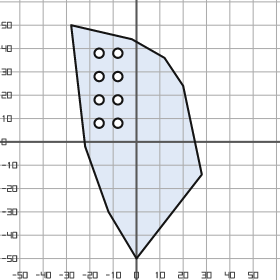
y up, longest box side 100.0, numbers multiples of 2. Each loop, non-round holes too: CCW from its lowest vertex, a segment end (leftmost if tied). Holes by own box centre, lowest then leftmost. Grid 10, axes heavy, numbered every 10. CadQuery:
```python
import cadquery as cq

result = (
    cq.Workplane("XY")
    .moveTo(0.0, -50.0)
    .lineTo(28.0, -14.0)
    .lineTo(20.0, 24.0)
    .lineTo(12.0, 36.0)
    .lineTo(-2.0, 44.0)
    .lineTo(-28.0, 50.0)
    .lineTo(-22.0, -2.0)
    .lineTo(-12.0, -30.0)
    .close()
    .moveTo(-16.0, 8.0)
    .circle(2.0)
    .moveTo(-8.0, 8.0)
    .circle(2.0)
    .moveTo(-16.0, 18.0)
    .circle(2.0)
    .moveTo(-8.0, 18.0)
    .circle(2.0)
    .moveTo(-16.0, 28.0)
    .circle(2.0)
    .moveTo(-8.0, 28.0)
    .circle(2.0)
    .moveTo(-16.0, 38.0)
    .circle(2.0)
    .moveTo(-8.0, 38.0)
    .circle(2.0)
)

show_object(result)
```